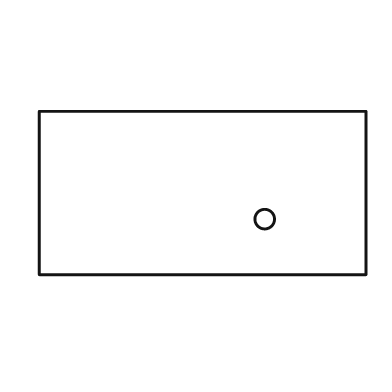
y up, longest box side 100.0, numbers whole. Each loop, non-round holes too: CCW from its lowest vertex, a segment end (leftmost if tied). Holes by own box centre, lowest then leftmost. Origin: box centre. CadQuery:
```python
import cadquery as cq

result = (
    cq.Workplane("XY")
    .moveTo(-50.0, -25.0)
    .lineTo(50.0, -25.0)
    .lineTo(50.0, 25.0)
    .lineTo(-50.0, 25.0)
    .close()
    .moveTo(19.0, -8.0)
    .circle(3.0)
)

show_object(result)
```